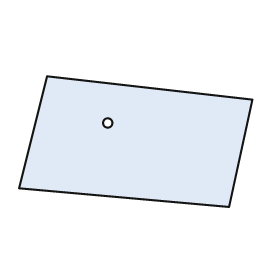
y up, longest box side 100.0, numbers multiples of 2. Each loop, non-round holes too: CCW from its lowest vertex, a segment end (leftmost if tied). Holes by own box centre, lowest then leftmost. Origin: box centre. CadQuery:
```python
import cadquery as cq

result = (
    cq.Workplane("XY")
    .moveTo(40.0, -28.0)
    .lineTo(50.0, 18.0)
    .lineTo(-38.0, 28.0)
    .lineTo(-50.0, -20.0)
    .close()
    .moveTo(-12.0, 8.0)
    .circle(2.0)
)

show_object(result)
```